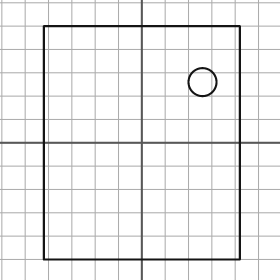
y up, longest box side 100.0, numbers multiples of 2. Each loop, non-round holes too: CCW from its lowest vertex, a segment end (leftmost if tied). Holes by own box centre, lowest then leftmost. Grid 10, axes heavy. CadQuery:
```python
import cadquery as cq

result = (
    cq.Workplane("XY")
    .moveTo(-42.0, -50.0)
    .lineTo(42.0, -50.0)
    .lineTo(42.0, 50.0)
    .lineTo(-42.0, 50.0)
    .close()
    .moveTo(26.0, 26.0)
    .circle(6.0)
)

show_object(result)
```